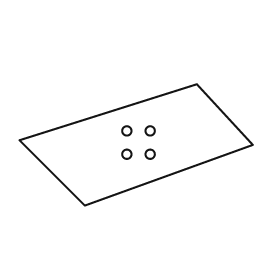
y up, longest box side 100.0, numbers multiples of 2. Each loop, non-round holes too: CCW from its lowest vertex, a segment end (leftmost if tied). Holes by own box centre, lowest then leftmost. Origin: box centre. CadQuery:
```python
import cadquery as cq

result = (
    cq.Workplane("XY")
    .moveTo(-22.0, -26.0)
    .lineTo(50.0, 0.0)
    .lineTo(26.0, 26.0)
    .lineTo(-50.0, 2.0)
    .close()
    .moveTo(-4.0, -4.0)
    .circle(2.0)
    .moveTo(6.0, -4.0)
    .circle(2.0)
    .moveTo(-4.0, 6.0)
    .circle(2.0)
    .moveTo(6.0, 6.0)
    .circle(2.0)
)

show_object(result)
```